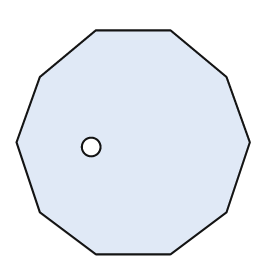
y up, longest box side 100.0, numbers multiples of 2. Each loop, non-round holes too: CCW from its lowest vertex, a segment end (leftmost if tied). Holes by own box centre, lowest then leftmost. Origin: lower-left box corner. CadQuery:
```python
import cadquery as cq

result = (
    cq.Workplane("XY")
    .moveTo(34.0, 0.0)
    .lineTo(66.0, 0.0)
    .lineTo(90.0, 18.0)
    .lineTo(100.0, 48.0)
    .lineTo(90.0, 76.0)
    .lineTo(66.0, 96.0)
    .lineTo(34.0, 96.0)
    .lineTo(10.0, 76.0)
    .lineTo(0.0, 48.0)
    .lineTo(10.0, 18.0)
    .close()
    .moveTo(32.0, 46.0)
    .circle(4.0)
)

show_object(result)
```